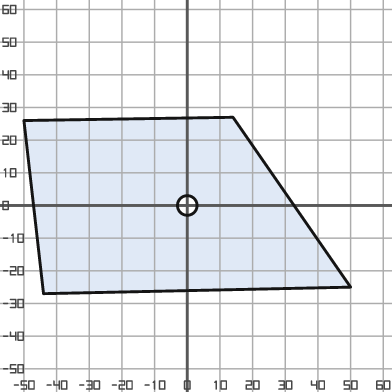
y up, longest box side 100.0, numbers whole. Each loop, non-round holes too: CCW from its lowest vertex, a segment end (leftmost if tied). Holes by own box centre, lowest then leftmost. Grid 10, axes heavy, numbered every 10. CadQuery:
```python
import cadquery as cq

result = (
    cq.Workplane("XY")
    .moveTo(-44.0, -27.0)
    .lineTo(50.0, -25.0)
    .lineTo(14.0, 27.0)
    .lineTo(-50.0, 26.0)
    .close()
    .moveTo(0.0, 0.0)
    .circle(3.0)
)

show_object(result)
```